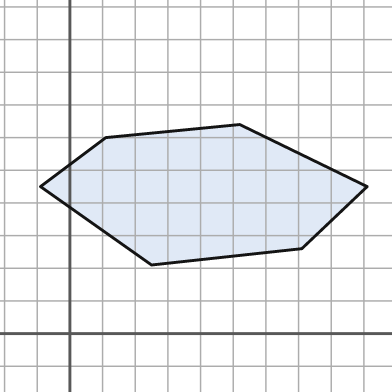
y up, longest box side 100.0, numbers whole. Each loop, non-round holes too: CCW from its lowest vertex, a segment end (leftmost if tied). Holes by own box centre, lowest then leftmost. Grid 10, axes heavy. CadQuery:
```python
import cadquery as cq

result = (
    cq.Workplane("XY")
    .moveTo(25.0, 21.0)
    .lineTo(71.0, 26.0)
    .lineTo(91.0, 45.0)
    .lineTo(52.0, 64.0)
    .lineTo(11.0, 60.0)
    .lineTo(-9.0, 45.0)
    .close()
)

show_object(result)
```